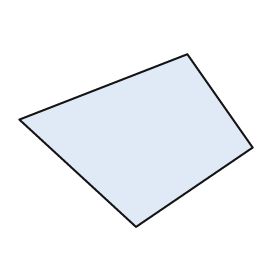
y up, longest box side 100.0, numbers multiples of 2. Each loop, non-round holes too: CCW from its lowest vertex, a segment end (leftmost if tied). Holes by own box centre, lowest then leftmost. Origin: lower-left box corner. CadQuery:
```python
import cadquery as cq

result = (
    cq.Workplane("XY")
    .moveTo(50.0, 0.0)
    .lineTo(100.0, 34.0)
    .lineTo(72.0, 74.0)
    .lineTo(0.0, 46.0)
    .close()
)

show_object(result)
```